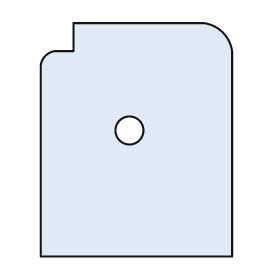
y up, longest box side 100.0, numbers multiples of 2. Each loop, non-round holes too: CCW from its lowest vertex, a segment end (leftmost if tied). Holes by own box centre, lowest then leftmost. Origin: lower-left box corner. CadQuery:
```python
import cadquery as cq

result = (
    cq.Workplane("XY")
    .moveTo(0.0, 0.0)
    .lineTo(82.0, 0.0)
    .lineTo(82.0, 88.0)
    .threePointArc((78.0, 96.0), (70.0, 100.0))
    .lineTo(14.0, 100.0)
    .lineTo(14.0, 88.0)
    .lineTo(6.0, 88.0)
    .threePointArc((2.0, 86.0), (0.0, 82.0))
    .close()
    .moveTo(38.0, 54.0)
    .circle(6.0)
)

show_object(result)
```